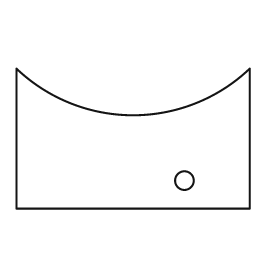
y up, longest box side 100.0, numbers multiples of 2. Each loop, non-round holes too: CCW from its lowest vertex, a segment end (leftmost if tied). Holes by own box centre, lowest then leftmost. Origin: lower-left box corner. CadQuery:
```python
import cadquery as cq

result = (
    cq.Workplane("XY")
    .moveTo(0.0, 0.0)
    .lineTo(100.0, 0.0)
    .lineTo(100.0, 60.0)
    .threePointArc((50.0, 40.0), (0.0, 60.0))
    .close()
    .moveTo(72.0, 12.0)
    .circle(4.0)
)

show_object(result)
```